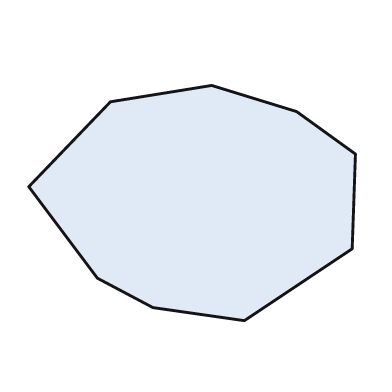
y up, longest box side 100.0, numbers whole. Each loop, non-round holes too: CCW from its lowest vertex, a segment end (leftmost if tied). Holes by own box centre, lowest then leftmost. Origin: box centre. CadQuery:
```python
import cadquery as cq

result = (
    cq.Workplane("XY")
    .moveTo(16.0, -36.0)
    .lineTo(49.0, -14.0)
    .lineTo(50.0, 15.0)
    .lineTo(32.0, 28.0)
    .lineTo(6.0, 36.0)
    .lineTo(-25.0, 31.0)
    .lineTo(-50.0, 5.0)
    .lineTo(-29.0, -23.0)
    .lineTo(-12.0, -32.0)
    .close()
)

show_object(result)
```